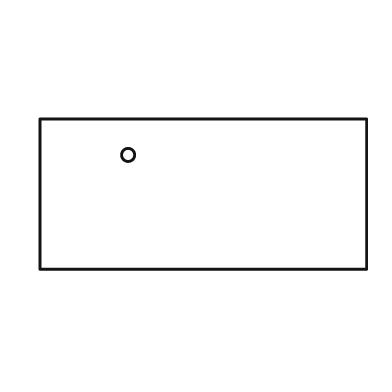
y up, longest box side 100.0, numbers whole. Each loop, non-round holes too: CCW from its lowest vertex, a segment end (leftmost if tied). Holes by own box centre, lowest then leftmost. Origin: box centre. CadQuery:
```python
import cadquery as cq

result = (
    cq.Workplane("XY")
    .moveTo(-50.0, -23.0)
    .lineTo(50.0, -23.0)
    .lineTo(50.0, 23.0)
    .lineTo(-50.0, 23.0)
    .close()
    .moveTo(-23.0, 12.0)
    .circle(2.0)
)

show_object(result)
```